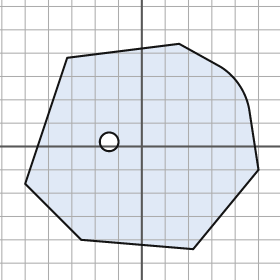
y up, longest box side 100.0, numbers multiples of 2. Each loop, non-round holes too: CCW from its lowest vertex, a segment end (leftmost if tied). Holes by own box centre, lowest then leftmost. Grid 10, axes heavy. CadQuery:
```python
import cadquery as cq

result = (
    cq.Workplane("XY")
    .moveTo(22.0, -44.0)
    .lineTo(50.0, -10.0)
    .lineTo(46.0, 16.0)
    .threePointArc((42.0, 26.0), (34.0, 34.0))
    .lineTo(16.0, 44.0)
    .lineTo(-32.0, 38.0)
    .lineTo(-50.0, -16.0)
    .lineTo(-26.0, -40.0)
    .close()
    .moveTo(-14.0, 2.0)
    .circle(4.0)
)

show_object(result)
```